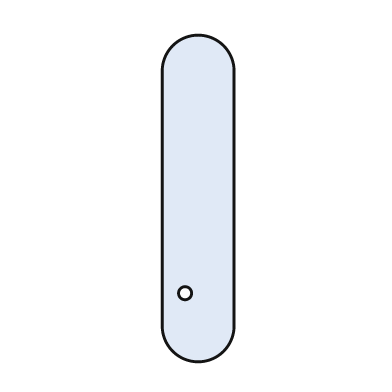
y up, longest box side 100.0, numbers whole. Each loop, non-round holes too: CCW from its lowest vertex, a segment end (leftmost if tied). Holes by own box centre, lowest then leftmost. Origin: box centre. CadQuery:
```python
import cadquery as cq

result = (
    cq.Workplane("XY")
    .moveTo(-11.0, -39.0)
    .threePointArc((0.0, -50.0), (11.0, -39.0))
    .lineTo(11.0, 39.0)
    .threePointArc((0.0, 50.0), (-11.0, 39.0))
    .close()
    .moveTo(-4.0, -29.0)
    .circle(2.0)
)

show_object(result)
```